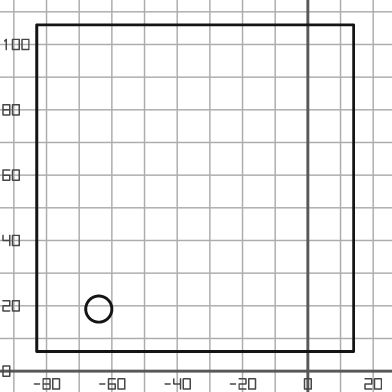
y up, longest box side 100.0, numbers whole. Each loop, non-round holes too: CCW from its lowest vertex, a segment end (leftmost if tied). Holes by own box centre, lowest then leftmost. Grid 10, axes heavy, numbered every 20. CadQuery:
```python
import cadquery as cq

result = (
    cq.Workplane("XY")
    .moveTo(-83.0, 6.0)
    .lineTo(14.0, 6.0)
    .lineTo(14.0, 106.0)
    .lineTo(-83.0, 106.0)
    .close()
    .moveTo(-64.0, 19.0)
    .circle(4.0)
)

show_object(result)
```